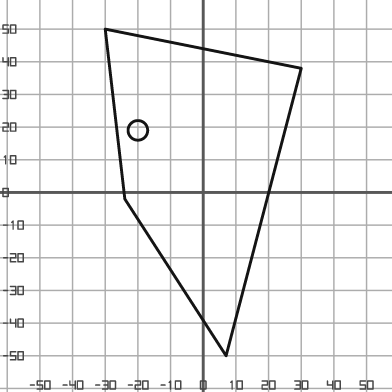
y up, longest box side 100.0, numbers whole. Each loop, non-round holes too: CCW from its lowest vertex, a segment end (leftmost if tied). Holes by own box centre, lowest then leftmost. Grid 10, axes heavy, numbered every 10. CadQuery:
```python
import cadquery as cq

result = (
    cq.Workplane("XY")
    .moveTo(7.0, -50.0)
    .lineTo(30.0, 38.0)
    .lineTo(-30.0, 50.0)
    .lineTo(-24.0, -2.0)
    .close()
    .moveTo(-20.0, 19.0)
    .circle(3.0)
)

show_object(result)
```